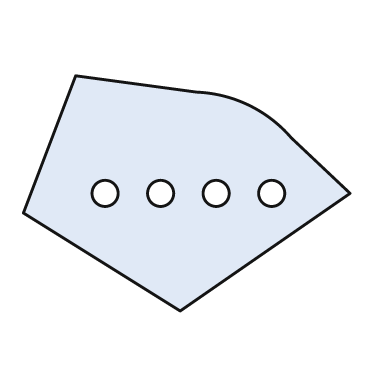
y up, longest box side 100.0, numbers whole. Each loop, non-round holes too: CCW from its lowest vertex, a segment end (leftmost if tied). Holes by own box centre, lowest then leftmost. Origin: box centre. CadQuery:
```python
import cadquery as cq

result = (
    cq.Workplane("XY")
    .moveTo(-2.0, -36.0)
    .lineTo(50.0, 0.0)
    .lineTo(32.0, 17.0)
    .threePointArc((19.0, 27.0), (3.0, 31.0))
    .lineTo(-34.0, 36.0)
    .lineTo(-50.0, -6.0)
    .close()
    .moveTo(-25.0, 0.0)
    .circle(4.0)
    .moveTo(-8.0, 0.0)
    .circle(4.0)
    .moveTo(9.0, 0.0)
    .circle(4.0)
    .moveTo(26.0, 0.0)
    .circle(4.0)
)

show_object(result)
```